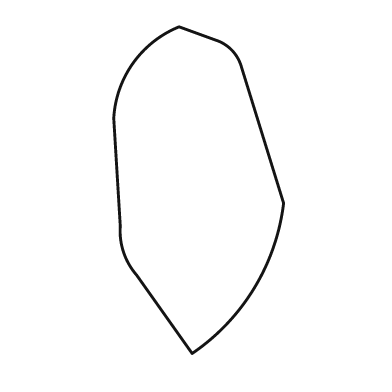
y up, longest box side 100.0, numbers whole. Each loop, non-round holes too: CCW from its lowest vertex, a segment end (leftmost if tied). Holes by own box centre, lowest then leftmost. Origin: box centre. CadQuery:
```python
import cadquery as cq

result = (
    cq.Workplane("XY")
    .moveTo(-2.0, -50.0)
    .threePointArc((17.0, -30.0), (26.0, -4.0))
    .lineTo(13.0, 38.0)
    .threePointArc((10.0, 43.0), (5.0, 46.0))
    .lineTo(-6.0, 50.0)
    .threePointArc((-20.0, 39.0), (-26.0, 22.0))
    .lineTo(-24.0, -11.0)
    .threePointArc((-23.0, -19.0), (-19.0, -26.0))
    .close()
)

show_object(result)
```